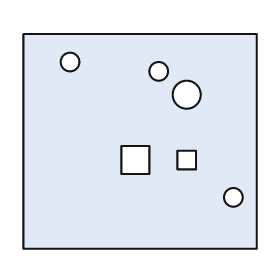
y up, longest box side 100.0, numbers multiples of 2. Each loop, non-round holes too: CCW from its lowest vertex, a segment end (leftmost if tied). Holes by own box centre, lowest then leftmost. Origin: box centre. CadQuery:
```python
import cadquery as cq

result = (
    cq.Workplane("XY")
    .moveTo(-50.0, -46.0)
    .lineTo(50.0, -46.0)
    .lineTo(50.0, 46.0)
    .lineTo(-50.0, 46.0)
    .close()
    .moveTo(40.0, -24.0)
    .circle(4.0)
    .moveTo(-8.0, -14.0)
    .lineTo(4.0, -14.0)
    .lineTo(4.0, -2.0)
    .lineTo(-8.0, -2.0)
    .close()
    .moveTo(16.0, -12.0)
    .lineTo(24.0, -12.0)
    .lineTo(24.0, -4.0)
    .lineTo(16.0, -4.0)
    .close()
    .moveTo(20.0, 20.0)
    .circle(6.0)
    .moveTo(8.0, 30.0)
    .circle(4.0)
    .moveTo(-30.0, 34.0)
    .circle(4.0)
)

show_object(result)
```